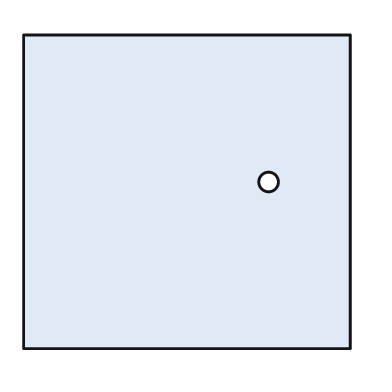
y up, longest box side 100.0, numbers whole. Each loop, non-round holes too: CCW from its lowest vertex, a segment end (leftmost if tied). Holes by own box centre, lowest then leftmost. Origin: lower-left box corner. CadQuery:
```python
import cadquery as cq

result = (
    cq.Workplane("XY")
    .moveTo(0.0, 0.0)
    .lineTo(100.0, 0.0)
    .lineTo(100.0, 96.0)
    .lineTo(0.0, 96.0)
    .close()
    .moveTo(75.0, 51.0)
    .circle(3.0)
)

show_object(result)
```